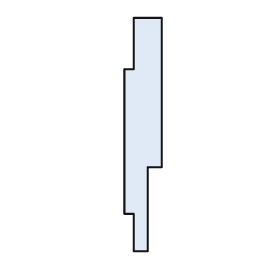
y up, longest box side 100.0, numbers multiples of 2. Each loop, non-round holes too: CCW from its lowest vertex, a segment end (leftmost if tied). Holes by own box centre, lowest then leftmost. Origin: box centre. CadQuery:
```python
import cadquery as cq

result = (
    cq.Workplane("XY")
    .moveTo(-4.0, -50.0)
    .lineTo(2.0, -50.0)
    .lineTo(2.0, -14.0)
    .lineTo(8.0, -14.0)
    .lineTo(8.0, 50.0)
    .lineTo(-4.0, 50.0)
    .lineTo(-4.0, 28.0)
    .lineTo(-8.0, 28.0)
    .lineTo(-8.0, -34.0)
    .lineTo(-4.0, -34.0)
    .close()
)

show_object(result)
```